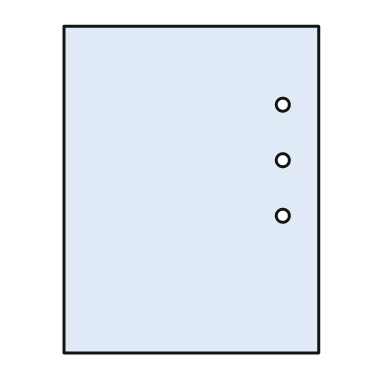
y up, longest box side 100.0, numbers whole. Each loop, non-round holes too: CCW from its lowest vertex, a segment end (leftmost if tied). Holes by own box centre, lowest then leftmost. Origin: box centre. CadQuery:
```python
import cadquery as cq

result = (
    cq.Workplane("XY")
    .moveTo(-39.0, -50.0)
    .lineTo(39.0, -50.0)
    .lineTo(39.0, 50.0)
    .lineTo(-39.0, 50.0)
    .close()
    .moveTo(28.0, -8.0)
    .circle(2.0)
    .moveTo(28.0, 9.0)
    .circle(2.0)
    .moveTo(28.0, 26.0)
    .circle(2.0)
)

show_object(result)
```